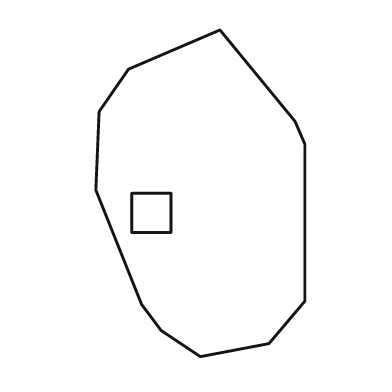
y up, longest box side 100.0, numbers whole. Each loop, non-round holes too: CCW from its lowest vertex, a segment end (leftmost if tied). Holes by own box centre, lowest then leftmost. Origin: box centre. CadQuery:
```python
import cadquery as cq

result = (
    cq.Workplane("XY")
    .moveTo(0.0, -50.0)
    .lineTo(21.0, -46.0)
    .lineTo(32.0, -33.0)
    .lineTo(32.0, 15.0)
    .lineTo(29.0, 22.0)
    .lineTo(6.0, 50.0)
    .lineTo(-22.0, 38.0)
    .lineTo(-31.0, 25.0)
    .lineTo(-32.0, 1.0)
    .lineTo(-18.0, -34.0)
    .lineTo(-12.0, -42.0)
    .close()
    .moveTo(-21.0, -12.0)
    .lineTo(-9.0, -12.0)
    .lineTo(-9.0, 0.0)
    .lineTo(-21.0, 0.0)
    .close()
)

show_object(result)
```